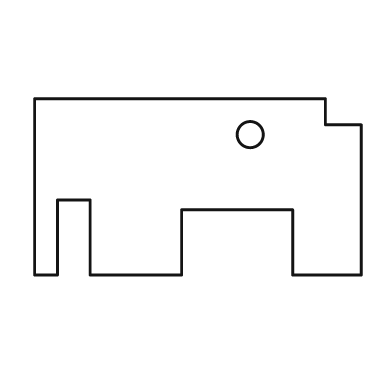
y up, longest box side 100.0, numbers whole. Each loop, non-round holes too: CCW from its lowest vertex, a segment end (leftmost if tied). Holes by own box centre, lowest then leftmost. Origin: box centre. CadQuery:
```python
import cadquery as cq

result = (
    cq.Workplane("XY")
    .moveTo(-50.0, -27.0)
    .lineTo(-43.0, -27.0)
    .lineTo(-43.0, -4.0)
    .lineTo(-33.0, -4.0)
    .lineTo(-33.0, -27.0)
    .lineTo(-5.0, -27.0)
    .lineTo(-5.0, -7.0)
    .lineTo(29.0, -7.0)
    .lineTo(29.0, -27.0)
    .lineTo(50.0, -27.0)
    .lineTo(50.0, 19.0)
    .lineTo(39.0, 19.0)
    .lineTo(39.0, 27.0)
    .lineTo(-50.0, 27.0)
    .close()
    .moveTo(16.0, 16.0)
    .circle(4.0)
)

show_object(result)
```